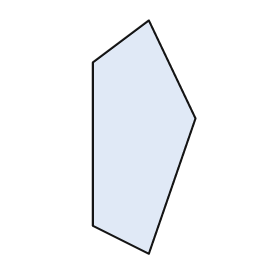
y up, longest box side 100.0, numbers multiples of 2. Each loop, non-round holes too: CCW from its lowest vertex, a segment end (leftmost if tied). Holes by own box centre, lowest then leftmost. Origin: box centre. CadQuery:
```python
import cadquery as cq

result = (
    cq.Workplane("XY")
    .moveTo(2.0, -50.0)
    .lineTo(22.0, 8.0)
    .lineTo(2.0, 50.0)
    .lineTo(-22.0, 32.0)
    .lineTo(-22.0, -38.0)
    .close()
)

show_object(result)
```